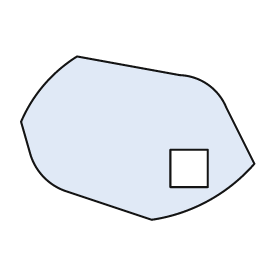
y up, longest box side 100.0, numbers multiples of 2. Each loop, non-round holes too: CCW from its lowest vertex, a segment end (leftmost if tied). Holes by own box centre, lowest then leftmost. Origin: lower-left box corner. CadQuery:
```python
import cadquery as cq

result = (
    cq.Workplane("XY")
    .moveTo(56.0, 0.0)
    .threePointArc((80.0, 8.0), (100.0, 24.0))
    .lineTo(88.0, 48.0)
    .threePointArc((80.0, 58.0), (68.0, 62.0))
    .lineTo(24.0, 70.0)
    .threePointArc((10.0, 58.0), (0.0, 42.0))
    .lineTo(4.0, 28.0)
    .threePointArc((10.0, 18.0), (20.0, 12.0))
    .close()
    .moveTo(64.0, 14.0)
    .lineTo(80.0, 14.0)
    .lineTo(80.0, 30.0)
    .lineTo(64.0, 30.0)
    .close()
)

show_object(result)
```